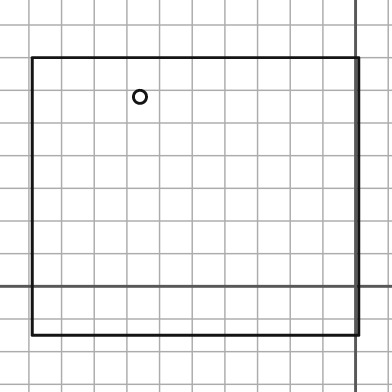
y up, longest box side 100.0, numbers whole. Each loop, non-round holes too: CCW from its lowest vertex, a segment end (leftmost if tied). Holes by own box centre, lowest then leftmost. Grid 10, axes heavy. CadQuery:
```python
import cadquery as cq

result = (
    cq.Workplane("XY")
    .moveTo(-99.0, -15.0)
    .lineTo(1.0, -15.0)
    .lineTo(1.0, 70.0)
    .lineTo(-99.0, 70.0)
    .close()
    .moveTo(-66.0, 58.0)
    .circle(2.0)
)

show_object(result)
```